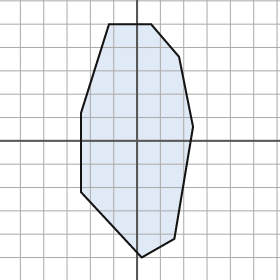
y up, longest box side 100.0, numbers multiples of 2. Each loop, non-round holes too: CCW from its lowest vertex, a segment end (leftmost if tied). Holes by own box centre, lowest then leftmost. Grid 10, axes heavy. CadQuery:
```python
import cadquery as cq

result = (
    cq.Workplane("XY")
    .moveTo(2.0, -50.0)
    .lineTo(16.0, -42.0)
    .lineTo(24.0, 6.0)
    .lineTo(18.0, 36.0)
    .lineTo(6.0, 50.0)
    .lineTo(-12.0, 50.0)
    .lineTo(-24.0, 12.0)
    .lineTo(-24.0, -22.0)
    .close()
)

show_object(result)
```